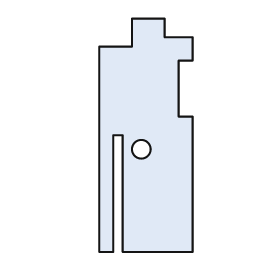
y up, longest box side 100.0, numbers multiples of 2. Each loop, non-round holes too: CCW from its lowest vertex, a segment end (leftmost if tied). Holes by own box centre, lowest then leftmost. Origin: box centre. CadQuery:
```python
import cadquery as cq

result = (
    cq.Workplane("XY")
    .moveTo(-20.0, -50.0)
    .lineTo(-14.0, -50.0)
    .lineTo(-14.0, 0.0)
    .lineTo(-10.0, 0.0)
    .lineTo(-10.0, -50.0)
    .lineTo(20.0, -50.0)
    .lineTo(20.0, 8.0)
    .lineTo(14.0, 8.0)
    .lineTo(14.0, 32.0)
    .lineTo(20.0, 32.0)
    .lineTo(20.0, 42.0)
    .lineTo(8.0, 42.0)
    .lineTo(8.0, 50.0)
    .lineTo(-6.0, 50.0)
    .lineTo(-6.0, 38.0)
    .lineTo(-20.0, 38.0)
    .close()
    .moveTo(-2.0, -6.0)
    .circle(4.0)
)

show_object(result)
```